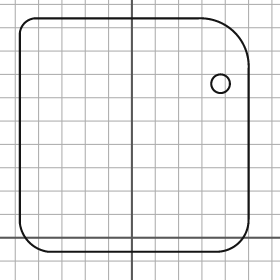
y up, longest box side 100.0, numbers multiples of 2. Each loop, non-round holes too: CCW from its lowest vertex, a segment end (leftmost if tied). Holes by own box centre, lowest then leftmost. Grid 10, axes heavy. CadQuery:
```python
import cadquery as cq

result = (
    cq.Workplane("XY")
    .moveTo(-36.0, -6.0)
    .lineTo(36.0, -6.0)
    .threePointArc((46.0, -2.0), (50.0, 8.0))
    .lineTo(50.0, 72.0)
    .threePointArc((44.0, 88.0), (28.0, 94.0))
    .lineTo(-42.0, 94.0)
    .threePointArc((-46.0, 92.0), (-48.0, 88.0))
    .lineTo(-48.0, 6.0)
    .threePointArc((-44.0, -2.0), (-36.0, -6.0))
    .close()
    .moveTo(38.0, 66.0)
    .circle(4.0)
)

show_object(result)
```